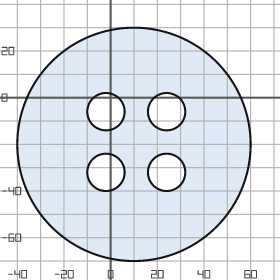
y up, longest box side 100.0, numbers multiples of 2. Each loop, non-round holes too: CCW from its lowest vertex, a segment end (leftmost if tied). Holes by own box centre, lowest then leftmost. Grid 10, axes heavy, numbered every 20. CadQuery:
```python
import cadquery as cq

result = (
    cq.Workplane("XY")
    .moveTo(10.0, -20.0)
    .circle(50.0)
    .moveTo(-2.0, -32.0)
    .circle(8.0)
    .moveTo(24.0, -32.0)
    .circle(8.0)
    .moveTo(-2.0, -6.0)
    .circle(8.0)
    .moveTo(24.0, -6.0)
    .circle(8.0)
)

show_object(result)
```